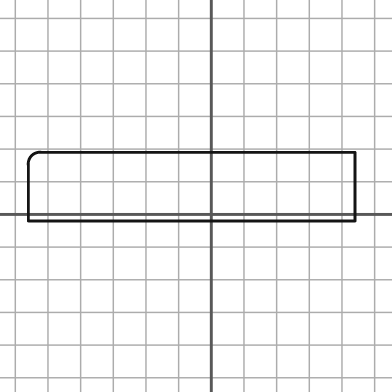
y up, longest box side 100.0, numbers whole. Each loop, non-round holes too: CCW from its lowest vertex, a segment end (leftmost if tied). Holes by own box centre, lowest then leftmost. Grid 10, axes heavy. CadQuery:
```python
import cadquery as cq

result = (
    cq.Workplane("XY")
    .moveTo(-56.0, -2.0)
    .lineTo(44.0, -2.0)
    .lineTo(44.0, 19.0)
    .lineTo(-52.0, 19.0)
    .threePointArc((-55.0, 18.0), (-56.0, 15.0))
    .close()
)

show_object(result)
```